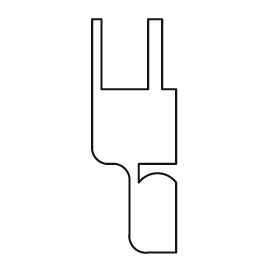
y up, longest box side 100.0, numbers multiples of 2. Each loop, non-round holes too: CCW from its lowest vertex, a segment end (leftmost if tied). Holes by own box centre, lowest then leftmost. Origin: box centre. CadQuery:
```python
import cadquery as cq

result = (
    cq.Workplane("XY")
    .moveTo(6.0, -50.0)
    .lineTo(18.0, -50.0)
    .lineTo(18.0, -20.0)
    .threePointArc((10.0, -16.0), (2.0, -20.0))
    .lineTo(2.0, -12.0)
    .lineTo(18.0, -12.0)
    .lineTo(18.0, 20.0)
    .lineTo(12.0, 20.0)
    .lineTo(12.0, 50.0)
    .lineTo(6.0, 50.0)
    .lineTo(6.0, 20.0)
    .lineTo(-14.0, 20.0)
    .lineTo(-14.0, 50.0)
    .lineTo(-18.0, 50.0)
    .lineTo(-18.0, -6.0)
    .threePointArc((-16.0, -10.0), (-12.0, -12.0))
    .lineTo(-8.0, -12.0)
    .threePointArc((-4.0, -14.0), (-2.0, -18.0))
    .lineTo(-2.0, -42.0)
    .threePointArc((0.0, -48.0), (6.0, -50.0))
    .close()
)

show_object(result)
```